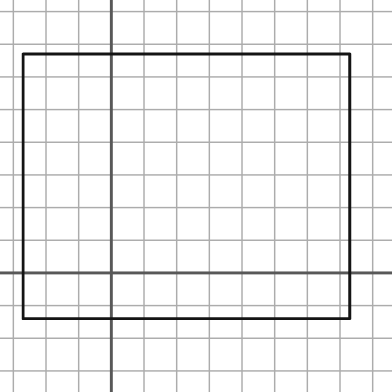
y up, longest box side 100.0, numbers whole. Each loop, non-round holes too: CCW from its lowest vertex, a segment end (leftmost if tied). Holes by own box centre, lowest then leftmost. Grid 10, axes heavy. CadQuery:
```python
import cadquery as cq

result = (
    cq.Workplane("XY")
    .moveTo(-27.0, -14.0)
    .lineTo(73.0, -14.0)
    .lineTo(73.0, 67.0)
    .lineTo(-27.0, 67.0)
    .close()
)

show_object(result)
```